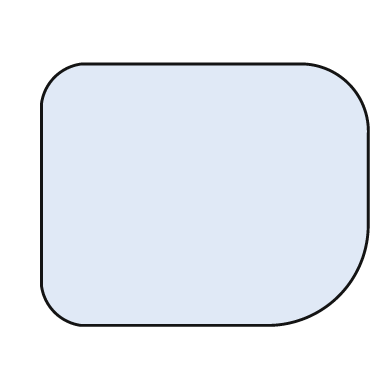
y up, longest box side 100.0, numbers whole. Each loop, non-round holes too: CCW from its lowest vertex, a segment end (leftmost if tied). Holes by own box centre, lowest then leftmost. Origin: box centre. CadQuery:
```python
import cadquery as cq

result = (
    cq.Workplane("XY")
    .moveTo(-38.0, -40.0)
    .lineTo(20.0, -40.0)
    .threePointArc((41.0, -31.0), (50.0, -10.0))
    .lineTo(50.0, 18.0)
    .threePointArc((44.0, 34.0), (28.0, 40.0))
    .lineTo(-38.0, 40.0)
    .threePointArc((-46.0, 36.0), (-50.0, 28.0))
    .lineTo(-50.0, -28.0)
    .threePointArc((-46.0, -36.0), (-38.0, -40.0))
    .close()
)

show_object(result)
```